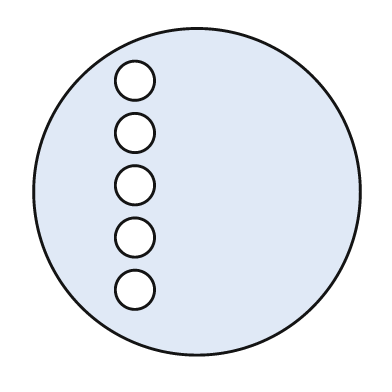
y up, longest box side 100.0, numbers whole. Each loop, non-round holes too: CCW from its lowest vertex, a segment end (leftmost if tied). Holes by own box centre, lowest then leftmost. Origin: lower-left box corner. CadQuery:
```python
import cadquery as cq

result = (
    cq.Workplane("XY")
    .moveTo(50.0, 50.0)
    .circle(50.0)
    .moveTo(31.0, 20.0)
    .circle(6.0)
    .moveTo(31.0, 36.0)
    .circle(6.0)
    .moveTo(31.0, 52.0)
    .circle(6.0)
    .moveTo(31.0, 68.0)
    .circle(6.0)
    .moveTo(31.0, 84.0)
    .circle(6.0)
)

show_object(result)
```